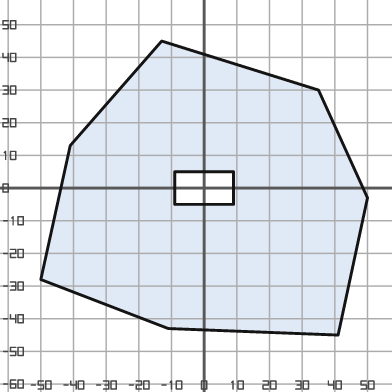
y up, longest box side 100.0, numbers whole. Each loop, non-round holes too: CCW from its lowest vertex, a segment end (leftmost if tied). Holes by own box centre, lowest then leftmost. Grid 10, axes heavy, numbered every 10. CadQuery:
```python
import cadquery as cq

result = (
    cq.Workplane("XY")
    .moveTo(41.0, -45.0)
    .lineTo(50.0, -3.0)
    .lineTo(35.0, 30.0)
    .lineTo(-13.0, 45.0)
    .lineTo(-41.0, 13.0)
    .lineTo(-50.0, -28.0)
    .lineTo(-11.0, -43.0)
    .close()
    .moveTo(-9.0, -5.0)
    .lineTo(9.0, -5.0)
    .lineTo(9.0, 5.0)
    .lineTo(-9.0, 5.0)
    .close()
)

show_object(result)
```